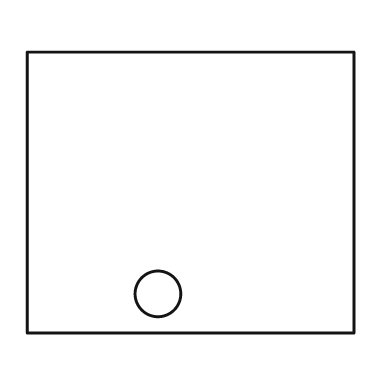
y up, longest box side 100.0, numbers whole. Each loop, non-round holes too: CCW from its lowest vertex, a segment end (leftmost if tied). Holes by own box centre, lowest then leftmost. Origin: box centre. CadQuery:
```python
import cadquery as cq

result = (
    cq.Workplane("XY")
    .moveTo(-50.0, -43.0)
    .lineTo(50.0, -43.0)
    .lineTo(50.0, 43.0)
    .lineTo(-50.0, 43.0)
    .close()
    .moveTo(-10.0, -31.0)
    .circle(7.0)
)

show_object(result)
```